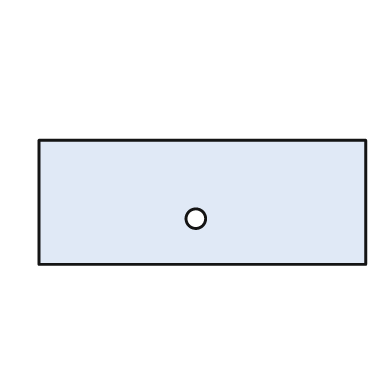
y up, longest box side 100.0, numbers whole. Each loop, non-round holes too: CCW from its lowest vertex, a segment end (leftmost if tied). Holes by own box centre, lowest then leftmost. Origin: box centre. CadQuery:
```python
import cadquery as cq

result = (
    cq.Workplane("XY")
    .moveTo(-50.0, -19.0)
    .lineTo(50.0, -19.0)
    .lineTo(50.0, 19.0)
    .lineTo(-50.0, 19.0)
    .close()
    .moveTo(-2.0, -5.0)
    .circle(3.0)
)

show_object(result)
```